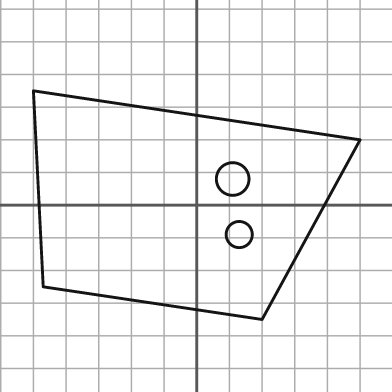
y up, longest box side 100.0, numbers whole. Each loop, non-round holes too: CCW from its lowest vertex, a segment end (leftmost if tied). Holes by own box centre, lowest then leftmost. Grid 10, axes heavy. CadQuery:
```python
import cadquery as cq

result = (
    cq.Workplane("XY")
    .moveTo(20.0, -35.0)
    .lineTo(50.0, 20.0)
    .lineTo(-50.0, 35.0)
    .lineTo(-47.0, -25.0)
    .close()
    .moveTo(13.0, -9.0)
    .circle(4.0)
    .moveTo(11.0, 8.0)
    .circle(5.0)
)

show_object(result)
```